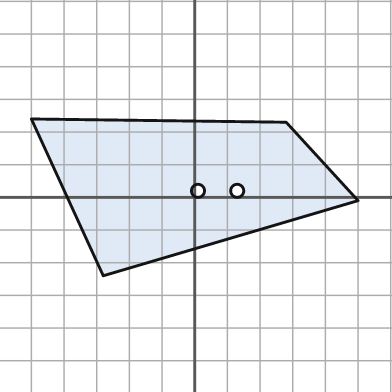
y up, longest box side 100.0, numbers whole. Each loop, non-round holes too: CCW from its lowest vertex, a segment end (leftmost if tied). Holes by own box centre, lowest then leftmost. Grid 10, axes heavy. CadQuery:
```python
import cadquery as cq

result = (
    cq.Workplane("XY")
    .moveTo(-28.0, -24.0)
    .lineTo(50.0, -1.0)
    .lineTo(28.0, 23.0)
    .lineTo(-50.0, 24.0)
    .close()
    .moveTo(1.0, 2.0)
    .circle(2.0)
    .moveTo(13.0, 2.0)
    .circle(2.0)
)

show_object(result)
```